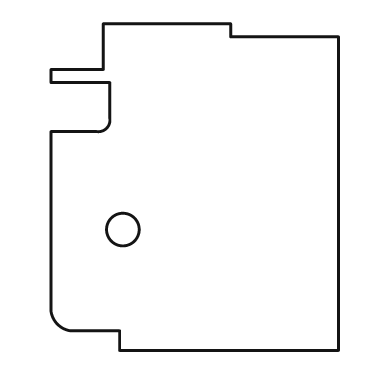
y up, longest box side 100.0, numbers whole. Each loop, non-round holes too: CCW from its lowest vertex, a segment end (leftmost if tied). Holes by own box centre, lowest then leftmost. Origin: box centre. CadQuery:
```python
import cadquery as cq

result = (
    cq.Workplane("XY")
    .moveTo(-23.0, -50.0)
    .lineTo(44.0, -50.0)
    .lineTo(44.0, 46.0)
    .lineTo(11.0, 46.0)
    .lineTo(11.0, 50.0)
    .lineTo(-28.0, 50.0)
    .lineTo(-28.0, 36.0)
    .lineTo(-44.0, 36.0)
    .lineTo(-44.0, 32.0)
    .lineTo(-26.0, 32.0)
    .lineTo(-26.0, 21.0)
    .threePointArc((-27.0, 18.0), (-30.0, 17.0))
    .lineTo(-44.0, 17.0)
    .lineTo(-44.0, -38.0)
    .threePointArc((-42.0, -42.0), (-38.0, -44.0))
    .lineTo(-23.0, -44.0)
    .close()
    .moveTo(-22.0, -13.0)
    .circle(5.0)
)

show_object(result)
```